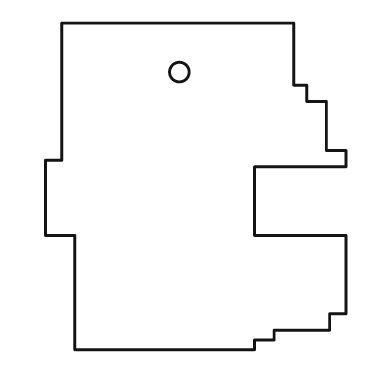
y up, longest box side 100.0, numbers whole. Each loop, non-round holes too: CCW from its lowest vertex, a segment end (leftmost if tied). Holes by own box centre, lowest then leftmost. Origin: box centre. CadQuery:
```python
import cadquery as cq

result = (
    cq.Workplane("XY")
    .moveTo(-37.0, -50.0)
    .lineTo(18.0, -50.0)
    .lineTo(18.0, -47.0)
    .lineTo(24.0, -47.0)
    .lineTo(24.0, -44.0)
    .lineTo(41.0, -44.0)
    .lineTo(41.0, -39.0)
    .lineTo(46.0, -39.0)
    .lineTo(46.0, -15.0)
    .lineTo(18.0, -15.0)
    .lineTo(18.0, 6.0)
    .lineTo(46.0, 6.0)
    .lineTo(46.0, 11.0)
    .lineTo(40.0, 11.0)
    .lineTo(40.0, 26.0)
    .lineTo(34.0, 26.0)
    .lineTo(34.0, 31.0)
    .lineTo(30.0, 31.0)
    .lineTo(30.0, 50.0)
    .lineTo(-41.0, 50.0)
    .lineTo(-41.0, 8.0)
    .lineTo(-46.0, 8.0)
    .lineTo(-46.0, -15.0)
    .lineTo(-37.0, -15.0)
    .close()
    .moveTo(-5.0, 35.0)
    .circle(3.0)
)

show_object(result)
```